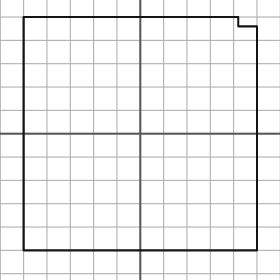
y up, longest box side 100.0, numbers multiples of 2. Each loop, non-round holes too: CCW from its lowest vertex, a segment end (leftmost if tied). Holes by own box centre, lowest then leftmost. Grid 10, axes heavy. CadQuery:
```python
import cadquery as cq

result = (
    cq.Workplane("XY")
    .moveTo(-50.0, -50.0)
    .lineTo(50.0, -50.0)
    .lineTo(50.0, 46.0)
    .lineTo(42.0, 46.0)
    .lineTo(42.0, 50.0)
    .lineTo(-50.0, 50.0)
    .close()
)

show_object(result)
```